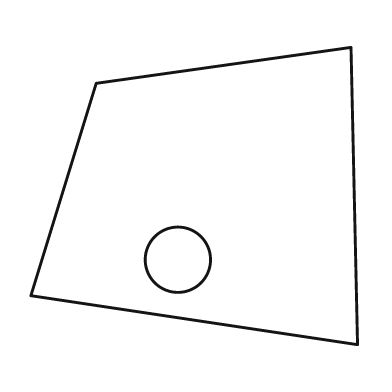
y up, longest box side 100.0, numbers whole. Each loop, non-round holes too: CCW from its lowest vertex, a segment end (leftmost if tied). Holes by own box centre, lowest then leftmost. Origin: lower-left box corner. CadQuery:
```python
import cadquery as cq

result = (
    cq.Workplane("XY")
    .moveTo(100.0, 0.0)
    .lineTo(98.0, 91.0)
    .lineTo(20.0, 80.0)
    .lineTo(0.0, 15.0)
    .close()
    .moveTo(45.0, 26.0)
    .circle(10.0)
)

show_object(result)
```